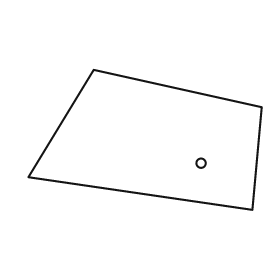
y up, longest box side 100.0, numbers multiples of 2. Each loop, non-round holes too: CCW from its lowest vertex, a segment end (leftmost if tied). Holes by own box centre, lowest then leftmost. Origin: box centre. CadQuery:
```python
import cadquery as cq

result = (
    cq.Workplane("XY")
    .moveTo(46.0, -30.0)
    .lineTo(50.0, 14.0)
    .lineTo(-22.0, 30.0)
    .lineTo(-50.0, -16.0)
    .close()
    .moveTo(24.0, -10.0)
    .circle(2.0)
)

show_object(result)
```